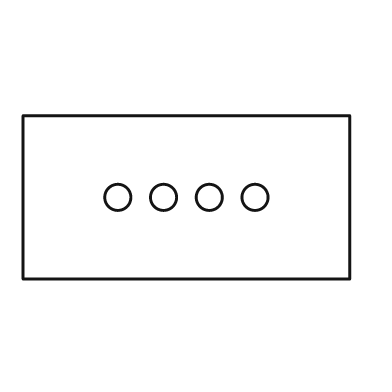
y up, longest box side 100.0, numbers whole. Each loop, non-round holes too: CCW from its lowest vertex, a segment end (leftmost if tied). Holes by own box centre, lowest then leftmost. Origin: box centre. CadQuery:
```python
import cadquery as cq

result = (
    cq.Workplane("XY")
    .moveTo(-50.0, -25.0)
    .lineTo(50.0, -25.0)
    .lineTo(50.0, 25.0)
    .lineTo(-50.0, 25.0)
    .close()
    .moveTo(-21.0, 0.0)
    .circle(4.0)
    .moveTo(-7.0, 0.0)
    .circle(4.0)
    .moveTo(7.0, 0.0)
    .circle(4.0)
    .moveTo(21.0, 0.0)
    .circle(4.0)
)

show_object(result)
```